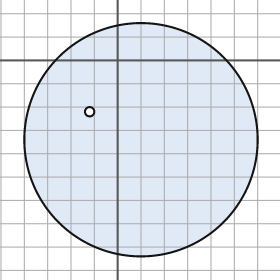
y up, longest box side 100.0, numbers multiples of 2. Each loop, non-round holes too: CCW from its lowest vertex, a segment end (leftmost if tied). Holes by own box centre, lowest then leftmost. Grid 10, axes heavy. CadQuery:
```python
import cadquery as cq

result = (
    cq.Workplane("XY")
    .moveTo(10.0, -34.0)
    .circle(50.0)
    .moveTo(-12.0, -22.0)
    .circle(2.0)
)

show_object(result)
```